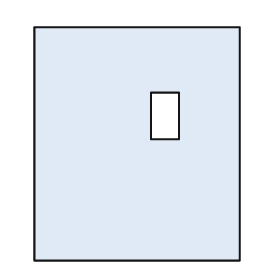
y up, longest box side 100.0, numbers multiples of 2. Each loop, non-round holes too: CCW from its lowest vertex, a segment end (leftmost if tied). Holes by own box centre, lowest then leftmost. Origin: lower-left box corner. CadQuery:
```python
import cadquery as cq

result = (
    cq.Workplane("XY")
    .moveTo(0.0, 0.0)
    .lineTo(88.0, 0.0)
    .lineTo(88.0, 100.0)
    .lineTo(0.0, 100.0)
    .close()
    .moveTo(50.0, 52.0)
    .lineTo(62.0, 52.0)
    .lineTo(62.0, 72.0)
    .lineTo(50.0, 72.0)
    .close()
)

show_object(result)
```